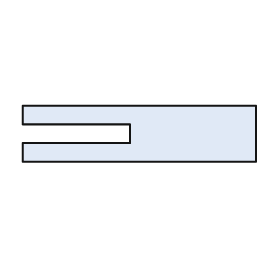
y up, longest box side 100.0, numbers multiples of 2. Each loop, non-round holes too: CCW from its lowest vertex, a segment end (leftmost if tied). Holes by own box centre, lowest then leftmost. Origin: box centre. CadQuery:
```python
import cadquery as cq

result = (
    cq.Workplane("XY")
    .moveTo(-50.0, -12.0)
    .lineTo(50.0, -12.0)
    .lineTo(50.0, 12.0)
    .lineTo(-50.0, 12.0)
    .lineTo(-50.0, 4.0)
    .lineTo(-4.0, 4.0)
    .lineTo(-4.0, -4.0)
    .lineTo(-50.0, -4.0)
    .close()
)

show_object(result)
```